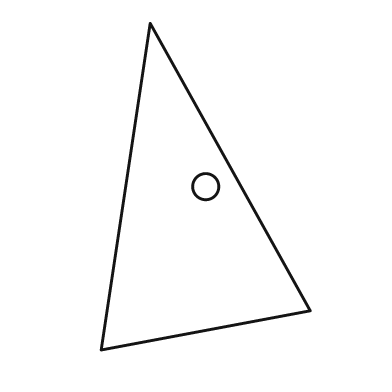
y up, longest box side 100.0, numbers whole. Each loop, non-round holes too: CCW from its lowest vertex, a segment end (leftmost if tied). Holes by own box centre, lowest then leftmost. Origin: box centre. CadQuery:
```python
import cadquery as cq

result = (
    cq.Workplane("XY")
    .moveTo(-32.0, -50.0)
    .lineTo(32.0, -38.0)
    .lineTo(-17.0, 50.0)
    .close()
    .moveTo(0.0, 0.0)
    .circle(4.0)
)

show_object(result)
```